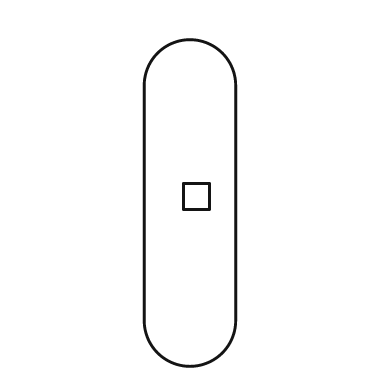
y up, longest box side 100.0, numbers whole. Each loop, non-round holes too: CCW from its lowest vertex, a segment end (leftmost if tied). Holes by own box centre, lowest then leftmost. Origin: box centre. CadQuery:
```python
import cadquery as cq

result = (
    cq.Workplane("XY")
    .moveTo(-14.0, -36.0)
    .threePointArc((0.0, -50.0), (14.0, -36.0))
    .lineTo(14.0, 36.0)
    .threePointArc((0.0, 50.0), (-14.0, 36.0))
    .close()
    .moveTo(-2.0, -2.0)
    .lineTo(6.0, -2.0)
    .lineTo(6.0, 6.0)
    .lineTo(-2.0, 6.0)
    .close()
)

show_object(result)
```